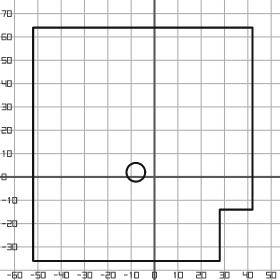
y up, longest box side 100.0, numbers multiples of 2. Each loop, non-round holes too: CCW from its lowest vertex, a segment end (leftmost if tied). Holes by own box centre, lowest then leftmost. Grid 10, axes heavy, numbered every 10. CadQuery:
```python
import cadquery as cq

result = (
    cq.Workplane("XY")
    .moveTo(-52.0, -36.0)
    .lineTo(28.0, -36.0)
    .lineTo(28.0, -14.0)
    .lineTo(42.0, -14.0)
    .lineTo(42.0, 64.0)
    .lineTo(-52.0, 64.0)
    .close()
    .moveTo(-8.0, 2.0)
    .circle(4.0)
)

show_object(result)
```